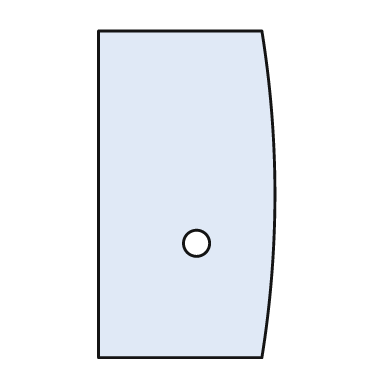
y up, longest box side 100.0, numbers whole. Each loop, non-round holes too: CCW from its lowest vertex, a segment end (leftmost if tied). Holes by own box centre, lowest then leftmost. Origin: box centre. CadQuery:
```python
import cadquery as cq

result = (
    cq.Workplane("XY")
    .moveTo(-27.0, -50.0)
    .lineTo(23.0, -50.0)
    .threePointArc((27.0, 0.0), (23.0, 50.0))
    .lineTo(-27.0, 50.0)
    .close()
    .moveTo(3.0, -15.0)
    .circle(4.0)
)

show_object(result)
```